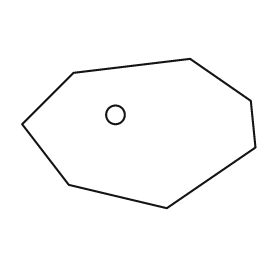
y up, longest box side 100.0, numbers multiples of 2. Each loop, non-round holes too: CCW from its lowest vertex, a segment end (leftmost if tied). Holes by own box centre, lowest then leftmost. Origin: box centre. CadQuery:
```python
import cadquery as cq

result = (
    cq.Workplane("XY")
    .moveTo(12.0, -32.0)
    .lineTo(50.0, -6.0)
    .lineTo(48.0, 14.0)
    .lineTo(22.0, 32.0)
    .lineTo(-28.0, 26.0)
    .lineTo(-50.0, 4.0)
    .lineTo(-30.0, -22.0)
    .close()
    .moveTo(-10.0, 8.0)
    .circle(4.0)
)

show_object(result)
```